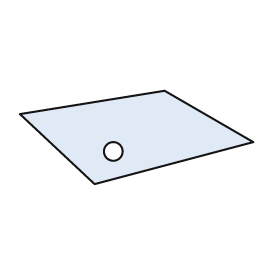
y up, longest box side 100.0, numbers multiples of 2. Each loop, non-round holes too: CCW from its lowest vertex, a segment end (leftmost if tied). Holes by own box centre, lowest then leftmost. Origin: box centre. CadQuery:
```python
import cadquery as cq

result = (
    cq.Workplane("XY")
    .moveTo(-18.0, -20.0)
    .lineTo(50.0, -2.0)
    .lineTo(12.0, 20.0)
    .lineTo(-50.0, 10.0)
    .close()
    .moveTo(-10.0, -6.0)
    .circle(4.0)
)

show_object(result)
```